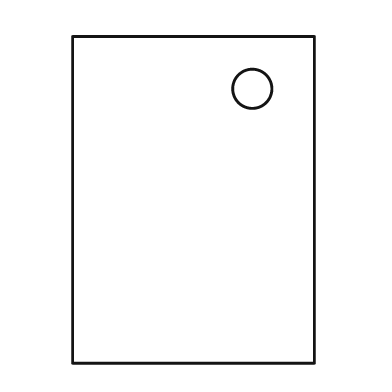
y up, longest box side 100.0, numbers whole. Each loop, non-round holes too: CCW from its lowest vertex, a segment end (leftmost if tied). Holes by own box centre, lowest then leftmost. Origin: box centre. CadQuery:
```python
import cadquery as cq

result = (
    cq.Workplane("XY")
    .moveTo(-37.0, -50.0)
    .lineTo(37.0, -50.0)
    .lineTo(37.0, 50.0)
    .lineTo(-37.0, 50.0)
    .close()
    .moveTo(18.0, 34.0)
    .circle(6.0)
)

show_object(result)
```